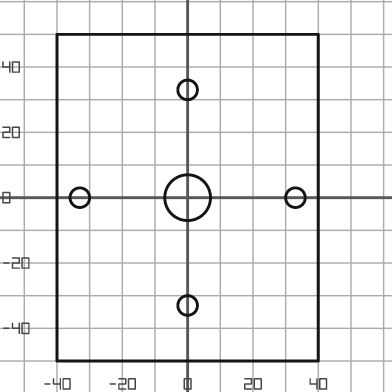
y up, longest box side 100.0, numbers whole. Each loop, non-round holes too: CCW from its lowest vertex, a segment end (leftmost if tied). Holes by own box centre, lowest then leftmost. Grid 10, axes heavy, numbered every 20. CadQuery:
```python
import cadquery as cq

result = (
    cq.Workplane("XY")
    .moveTo(-40.0, -50.0)
    .lineTo(40.0, -50.0)
    .lineTo(40.0, 50.0)
    .lineTo(-40.0, 50.0)
    .close()
    .moveTo(0.0, -33.0)
    .circle(3.0)
    .moveTo(-33.0, 0.0)
    .circle(3.0)
    .moveTo(0.0, 0.0)
    .circle(7.0)
    .moveTo(33.0, 0.0)
    .circle(3.0)
    .moveTo(0.0, 33.0)
    .circle(3.0)
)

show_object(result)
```